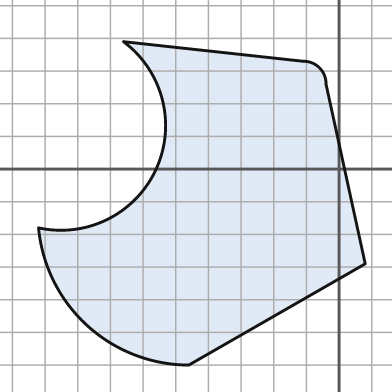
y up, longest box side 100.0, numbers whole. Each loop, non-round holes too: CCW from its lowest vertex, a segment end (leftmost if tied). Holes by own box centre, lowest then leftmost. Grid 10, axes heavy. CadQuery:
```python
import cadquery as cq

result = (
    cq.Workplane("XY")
    .moveTo(-46.0, -60.0)
    .lineTo(8.0, -29.0)
    .lineTo(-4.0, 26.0)
    .threePointArc((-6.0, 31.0), (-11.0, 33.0))
    .lineTo(-66.0, 39.0)
    .threePointArc((-56.0, 0.0), (-92.0, -18.0))
    .threePointArc((-77.0, -48.0), (-46.0, -60.0))
    .close()
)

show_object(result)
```